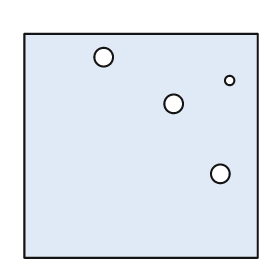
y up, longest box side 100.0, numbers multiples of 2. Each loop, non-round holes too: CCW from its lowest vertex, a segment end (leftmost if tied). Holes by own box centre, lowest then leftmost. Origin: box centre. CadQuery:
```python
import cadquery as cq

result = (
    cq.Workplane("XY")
    .moveTo(-50.0, -48.0)
    .lineTo(50.0, -48.0)
    .lineTo(50.0, 48.0)
    .lineTo(-50.0, 48.0)
    .close()
    .moveTo(34.0, -12.0)
    .circle(4.0)
    .moveTo(14.0, 18.0)
    .circle(4.0)
    .moveTo(38.0, 28.0)
    .circle(2.0)
    .moveTo(-16.0, 38.0)
    .circle(4.0)
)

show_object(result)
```